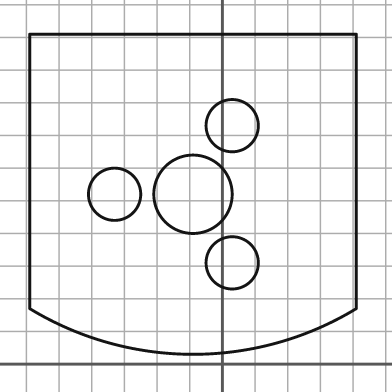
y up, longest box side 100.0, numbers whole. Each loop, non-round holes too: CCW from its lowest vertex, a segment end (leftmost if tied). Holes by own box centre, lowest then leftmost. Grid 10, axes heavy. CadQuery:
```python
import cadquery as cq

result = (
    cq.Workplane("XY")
    .moveTo(-59.0, 17.0)
    .threePointArc((-9.0, 3.0), (41.0, 17.0))
    .lineTo(41.0, 101.0)
    .lineTo(-59.0, 101.0)
    .close()
    .moveTo(3.0, 31.0)
    .circle(8.0)
    .moveTo(-33.0, 52.0)
    .circle(8.0)
    .moveTo(-9.0, 52.0)
    .circle(12.0)
    .moveTo(3.0, 73.0)
    .circle(8.0)
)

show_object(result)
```